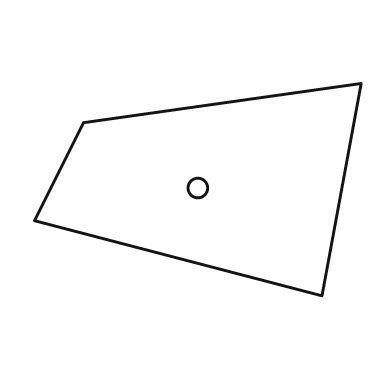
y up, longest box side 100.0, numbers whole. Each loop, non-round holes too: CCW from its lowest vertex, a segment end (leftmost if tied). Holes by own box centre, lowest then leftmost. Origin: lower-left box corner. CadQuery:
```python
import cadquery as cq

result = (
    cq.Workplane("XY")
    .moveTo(88.0, 0.0)
    .lineTo(100.0, 65.0)
    .lineTo(15.0, 53.0)
    .lineTo(0.0, 23.0)
    .close()
    .moveTo(50.0, 33.0)
    .circle(3.0)
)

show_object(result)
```